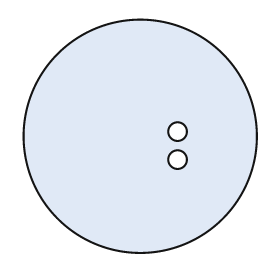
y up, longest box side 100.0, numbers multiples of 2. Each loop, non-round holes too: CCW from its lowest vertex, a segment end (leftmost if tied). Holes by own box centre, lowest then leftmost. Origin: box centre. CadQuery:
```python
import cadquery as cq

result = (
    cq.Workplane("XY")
    .moveTo(0.0, 0.0)
    .circle(50.0)
    .moveTo(16.0, -10.0)
    .circle(4.0)
    .moveTo(16.0, 2.0)
    .circle(4.0)
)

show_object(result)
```